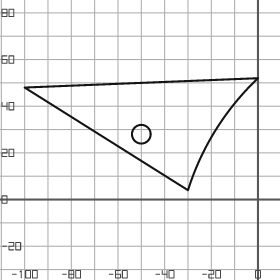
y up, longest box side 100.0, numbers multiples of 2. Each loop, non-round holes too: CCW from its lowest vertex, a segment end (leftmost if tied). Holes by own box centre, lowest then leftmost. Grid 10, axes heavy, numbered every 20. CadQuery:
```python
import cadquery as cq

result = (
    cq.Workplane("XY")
    .moveTo(-30.0, 4.0)
    .threePointArc((-18.0, 30.0), (0.0, 52.0))
    .lineTo(-100.0, 48.0)
    .close()
    .moveTo(-50.0, 28.0)
    .circle(4.0)
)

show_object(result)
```